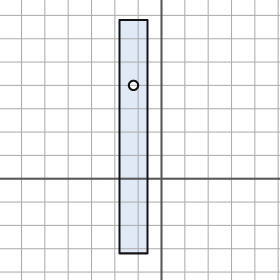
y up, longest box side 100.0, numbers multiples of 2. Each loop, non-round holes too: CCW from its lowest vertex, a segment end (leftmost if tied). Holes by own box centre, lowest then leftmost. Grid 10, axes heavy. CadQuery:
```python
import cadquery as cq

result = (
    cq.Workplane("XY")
    .moveTo(-18.0, -32.0)
    .lineTo(-6.0, -32.0)
    .lineTo(-6.0, 68.0)
    .lineTo(-18.0, 68.0)
    .close()
    .moveTo(-12.0, 40.0)
    .circle(2.0)
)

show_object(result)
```